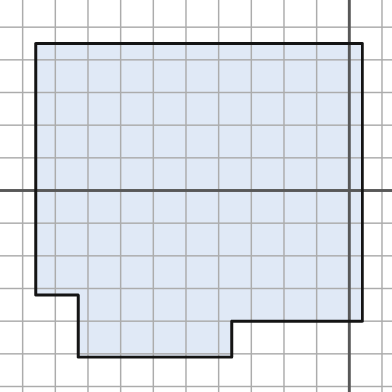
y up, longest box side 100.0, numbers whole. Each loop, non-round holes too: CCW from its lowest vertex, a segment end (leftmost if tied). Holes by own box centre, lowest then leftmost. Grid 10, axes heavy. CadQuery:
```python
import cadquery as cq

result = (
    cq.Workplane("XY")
    .moveTo(-83.0, -51.0)
    .lineTo(-36.0, -51.0)
    .lineTo(-36.0, -40.0)
    .lineTo(4.0, -40.0)
    .lineTo(4.0, 45.0)
    .lineTo(-96.0, 45.0)
    .lineTo(-96.0, -32.0)
    .lineTo(-83.0, -32.0)
    .close()
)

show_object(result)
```